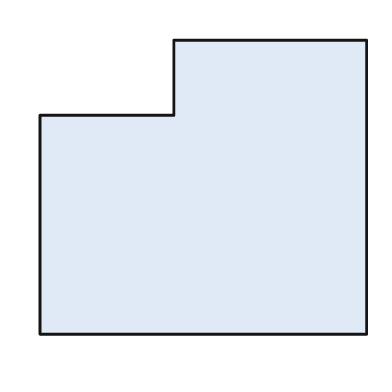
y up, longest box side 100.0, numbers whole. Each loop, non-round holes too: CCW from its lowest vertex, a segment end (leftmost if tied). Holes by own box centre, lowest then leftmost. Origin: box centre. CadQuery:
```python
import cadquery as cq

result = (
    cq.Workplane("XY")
    .moveTo(-50.0, -45.0)
    .lineTo(50.0, -45.0)
    .lineTo(50.0, 45.0)
    .lineTo(-9.0, 45.0)
    .lineTo(-9.0, 22.0)
    .lineTo(-50.0, 22.0)
    .close()
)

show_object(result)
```